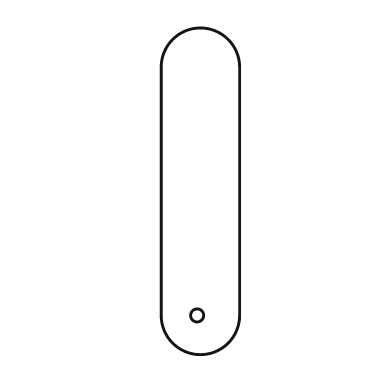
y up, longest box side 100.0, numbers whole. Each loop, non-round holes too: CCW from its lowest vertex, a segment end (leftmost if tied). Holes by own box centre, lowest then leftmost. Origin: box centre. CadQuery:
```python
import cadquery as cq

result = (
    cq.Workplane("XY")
    .moveTo(-12.0, -38.0)
    .threePointArc((0.0, -50.0), (12.0, -38.0))
    .lineTo(12.0, 38.0)
    .threePointArc((0.0, 50.0), (-12.0, 38.0))
    .close()
    .moveTo(-1.0, -38.0)
    .circle(2.0)
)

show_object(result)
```